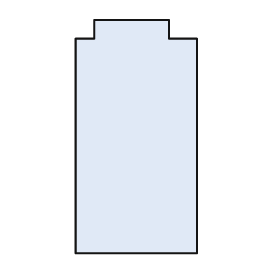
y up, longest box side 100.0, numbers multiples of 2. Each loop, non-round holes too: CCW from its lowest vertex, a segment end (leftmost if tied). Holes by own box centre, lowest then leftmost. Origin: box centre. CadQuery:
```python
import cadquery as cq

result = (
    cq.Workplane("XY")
    .moveTo(-26.0, -50.0)
    .lineTo(26.0, -50.0)
    .lineTo(26.0, 42.0)
    .lineTo(14.0, 42.0)
    .lineTo(14.0, 50.0)
    .lineTo(-18.0, 50.0)
    .lineTo(-18.0, 42.0)
    .lineTo(-26.0, 42.0)
    .close()
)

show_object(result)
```